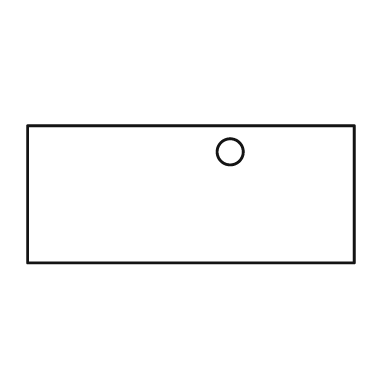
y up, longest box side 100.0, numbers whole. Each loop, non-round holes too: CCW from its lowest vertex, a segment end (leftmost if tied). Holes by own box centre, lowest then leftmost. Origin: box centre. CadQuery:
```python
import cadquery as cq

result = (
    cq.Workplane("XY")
    .moveTo(-50.0, -21.0)
    .lineTo(50.0, -21.0)
    .lineTo(50.0, 21.0)
    .lineTo(-50.0, 21.0)
    .close()
    .moveTo(12.0, 13.0)
    .circle(4.0)
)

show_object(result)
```